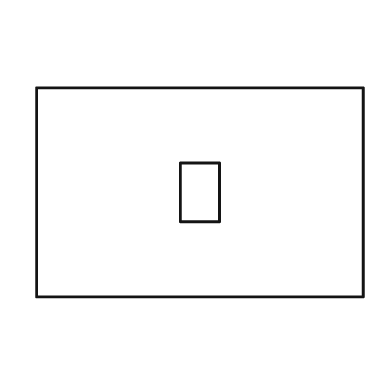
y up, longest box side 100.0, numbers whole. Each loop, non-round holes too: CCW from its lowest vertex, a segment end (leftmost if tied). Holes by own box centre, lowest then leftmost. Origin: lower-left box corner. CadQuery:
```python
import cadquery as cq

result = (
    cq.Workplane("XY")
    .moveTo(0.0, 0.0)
    .lineTo(100.0, 0.0)
    .lineTo(100.0, 64.0)
    .lineTo(0.0, 64.0)
    .close()
    .moveTo(44.0, 23.0)
    .lineTo(56.0, 23.0)
    .lineTo(56.0, 41.0)
    .lineTo(44.0, 41.0)
    .close()
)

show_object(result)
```